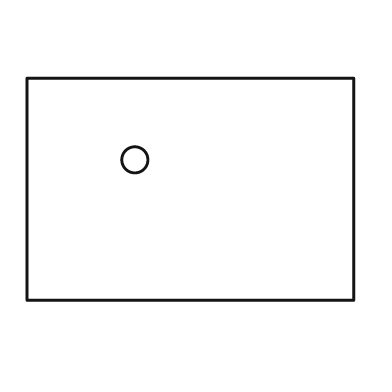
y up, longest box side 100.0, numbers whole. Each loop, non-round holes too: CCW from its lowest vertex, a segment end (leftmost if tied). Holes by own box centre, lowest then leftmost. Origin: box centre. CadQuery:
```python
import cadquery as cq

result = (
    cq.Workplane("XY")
    .moveTo(-50.0, -34.0)
    .lineTo(50.0, -34.0)
    .lineTo(50.0, 34.0)
    .lineTo(-50.0, 34.0)
    .close()
    .moveTo(-17.0, 9.0)
    .circle(4.0)
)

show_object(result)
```